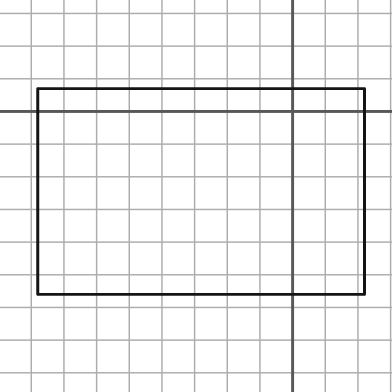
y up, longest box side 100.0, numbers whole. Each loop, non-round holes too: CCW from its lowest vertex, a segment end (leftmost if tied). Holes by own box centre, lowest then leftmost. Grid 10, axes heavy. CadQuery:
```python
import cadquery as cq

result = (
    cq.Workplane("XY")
    .moveTo(-78.0, -56.0)
    .lineTo(22.0, -56.0)
    .lineTo(22.0, 7.0)
    .lineTo(-78.0, 7.0)
    .close()
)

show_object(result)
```